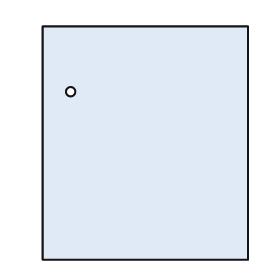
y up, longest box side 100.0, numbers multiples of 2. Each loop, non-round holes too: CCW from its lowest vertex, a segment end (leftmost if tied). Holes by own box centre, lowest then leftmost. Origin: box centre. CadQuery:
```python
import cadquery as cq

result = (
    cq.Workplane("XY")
    .moveTo(-44.0, -50.0)
    .lineTo(44.0, -50.0)
    .lineTo(44.0, 50.0)
    .lineTo(-44.0, 50.0)
    .close()
    .moveTo(-32.0, 22.0)
    .circle(2.0)
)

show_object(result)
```